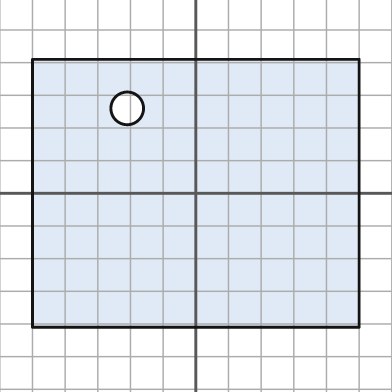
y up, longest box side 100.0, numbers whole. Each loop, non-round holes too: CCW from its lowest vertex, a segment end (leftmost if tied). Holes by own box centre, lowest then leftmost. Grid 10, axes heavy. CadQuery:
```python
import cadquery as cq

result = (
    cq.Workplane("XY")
    .moveTo(-50.0, -41.0)
    .lineTo(50.0, -41.0)
    .lineTo(50.0, 41.0)
    .lineTo(-50.0, 41.0)
    .close()
    .moveTo(-21.0, 26.0)
    .circle(5.0)
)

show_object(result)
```